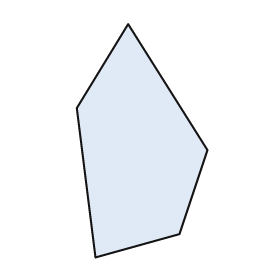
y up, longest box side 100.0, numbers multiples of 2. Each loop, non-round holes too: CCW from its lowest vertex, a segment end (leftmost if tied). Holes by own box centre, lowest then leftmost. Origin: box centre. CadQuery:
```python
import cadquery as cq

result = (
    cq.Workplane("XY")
    .moveTo(-20.0, -50.0)
    .lineTo(16.0, -40.0)
    .lineTo(28.0, -4.0)
    .lineTo(-6.0, 50.0)
    .lineTo(-28.0, 14.0)
    .close()
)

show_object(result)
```